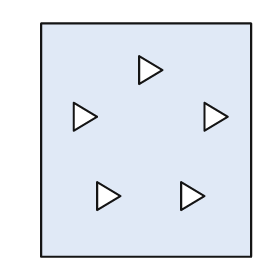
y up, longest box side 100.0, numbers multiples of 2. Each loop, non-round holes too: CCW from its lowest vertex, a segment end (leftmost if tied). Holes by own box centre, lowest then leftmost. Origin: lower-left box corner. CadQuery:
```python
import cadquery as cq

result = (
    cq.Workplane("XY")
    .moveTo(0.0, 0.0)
    .lineTo(90.0, 0.0)
    .lineTo(90.0, 100.0)
    .lineTo(0.0, 100.0)
    .close()
    .moveTo(24.0, 20.0)
    .lineTo(34.0, 26.0)
    .lineTo(24.0, 32.0)
    .close()
    .moveTo(60.0, 20.0)
    .lineTo(70.0, 26.0)
    .lineTo(60.0, 32.0)
    .close()
    .moveTo(14.0, 54.0)
    .lineTo(24.0, 60.0)
    .lineTo(14.0, 66.0)
    .close()
    .moveTo(70.0, 54.0)
    .lineTo(80.0, 60.0)
    .lineTo(70.0, 66.0)
    .close()
    .moveTo(42.0, 74.0)
    .lineTo(52.0, 80.0)
    .lineTo(42.0, 86.0)
    .close()
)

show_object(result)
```